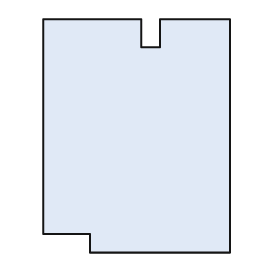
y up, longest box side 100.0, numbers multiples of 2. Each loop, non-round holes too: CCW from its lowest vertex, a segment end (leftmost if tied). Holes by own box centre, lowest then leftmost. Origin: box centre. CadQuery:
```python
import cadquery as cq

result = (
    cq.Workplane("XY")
    .moveTo(-20.0, -50.0)
    .lineTo(40.0, -50.0)
    .lineTo(40.0, 50.0)
    .lineTo(10.0, 50.0)
    .lineTo(10.0, 38.0)
    .lineTo(2.0, 38.0)
    .lineTo(2.0, 50.0)
    .lineTo(-40.0, 50.0)
    .lineTo(-40.0, -42.0)
    .lineTo(-20.0, -42.0)
    .close()
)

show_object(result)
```